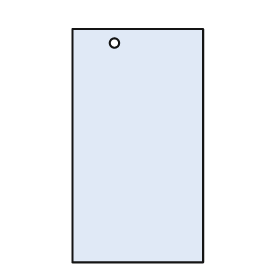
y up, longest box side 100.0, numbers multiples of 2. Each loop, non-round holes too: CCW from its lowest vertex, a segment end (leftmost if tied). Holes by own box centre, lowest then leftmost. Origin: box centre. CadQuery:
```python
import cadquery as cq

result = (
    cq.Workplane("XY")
    .moveTo(-28.0, -50.0)
    .lineTo(28.0, -50.0)
    .lineTo(28.0, 50.0)
    .lineTo(-28.0, 50.0)
    .close()
    .moveTo(-10.0, 44.0)
    .circle(2.0)
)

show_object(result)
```